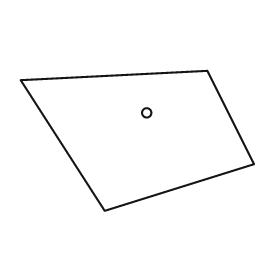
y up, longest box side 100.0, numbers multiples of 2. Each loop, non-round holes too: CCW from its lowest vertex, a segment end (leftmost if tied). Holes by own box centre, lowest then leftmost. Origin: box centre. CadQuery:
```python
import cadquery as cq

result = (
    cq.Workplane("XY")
    .moveTo(-14.0, -30.0)
    .lineTo(50.0, -10.0)
    .lineTo(30.0, 30.0)
    .lineTo(-50.0, 26.0)
    .close()
    .moveTo(4.0, 12.0)
    .circle(2.0)
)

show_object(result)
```